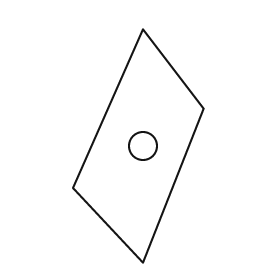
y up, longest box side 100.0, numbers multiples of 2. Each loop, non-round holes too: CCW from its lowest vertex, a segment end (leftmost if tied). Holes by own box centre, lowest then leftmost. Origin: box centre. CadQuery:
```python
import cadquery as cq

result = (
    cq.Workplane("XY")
    .moveTo(2.0, -50.0)
    .lineTo(28.0, 16.0)
    .lineTo(2.0, 50.0)
    .lineTo(-28.0, -18.0)
    .close()
    .moveTo(2.0, 0.0)
    .circle(6.0)
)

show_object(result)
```